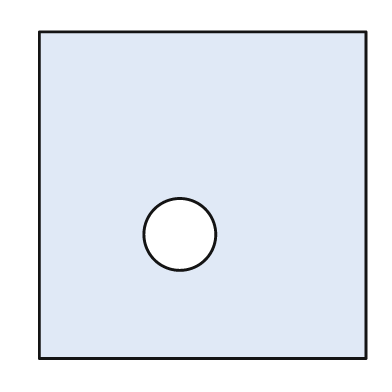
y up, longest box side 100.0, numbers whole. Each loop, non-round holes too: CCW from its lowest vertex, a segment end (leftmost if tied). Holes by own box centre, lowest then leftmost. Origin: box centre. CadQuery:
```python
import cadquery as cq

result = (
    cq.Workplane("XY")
    .moveTo(-50.0, -50.0)
    .lineTo(50.0, -50.0)
    .lineTo(50.0, 50.0)
    .lineTo(-50.0, 50.0)
    .close()
    .moveTo(-7.0, -12.0)
    .circle(11.0)
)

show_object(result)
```